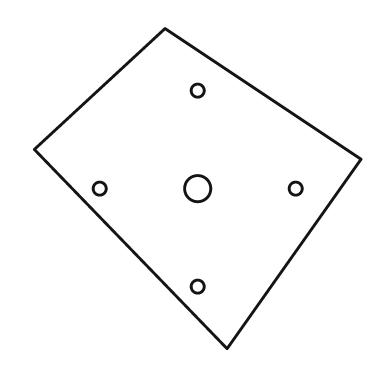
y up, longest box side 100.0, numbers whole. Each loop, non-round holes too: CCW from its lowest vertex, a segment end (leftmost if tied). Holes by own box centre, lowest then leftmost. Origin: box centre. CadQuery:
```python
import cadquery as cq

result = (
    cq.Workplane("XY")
    .moveTo(9.0, -49.0)
    .lineTo(50.0, 9.0)
    .lineTo(-10.0, 49.0)
    .lineTo(-50.0, 12.0)
    .close()
    .moveTo(0.0, -30.0)
    .circle(2.0)
    .moveTo(-30.0, 0.0)
    .circle(2.0)
    .moveTo(0.0, 0.0)
    .circle(4.0)
    .moveTo(30.0, 0.0)
    .circle(2.0)
    .moveTo(0.0, 30.0)
    .circle(2.0)
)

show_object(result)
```